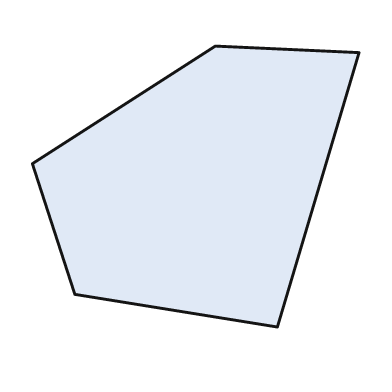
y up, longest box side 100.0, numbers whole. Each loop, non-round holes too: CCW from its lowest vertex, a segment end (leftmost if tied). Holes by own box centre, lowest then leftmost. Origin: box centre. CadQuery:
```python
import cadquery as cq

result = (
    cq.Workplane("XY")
    .moveTo(25.0, -43.0)
    .lineTo(50.0, 41.0)
    .lineTo(6.0, 43.0)
    .lineTo(-50.0, 7.0)
    .lineTo(-37.0, -33.0)
    .close()
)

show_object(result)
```